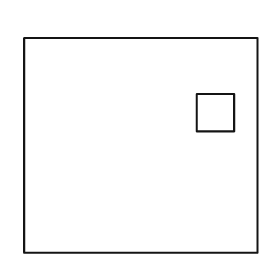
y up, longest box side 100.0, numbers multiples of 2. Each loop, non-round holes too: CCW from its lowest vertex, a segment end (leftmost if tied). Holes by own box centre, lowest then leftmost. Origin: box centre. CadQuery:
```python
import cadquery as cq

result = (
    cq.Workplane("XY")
    .moveTo(-50.0, -46.0)
    .lineTo(50.0, -46.0)
    .lineTo(50.0, 46.0)
    .lineTo(-50.0, 46.0)
    .close()
    .moveTo(24.0, 6.0)
    .lineTo(40.0, 6.0)
    .lineTo(40.0, 22.0)
    .lineTo(24.0, 22.0)
    .close()
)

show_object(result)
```